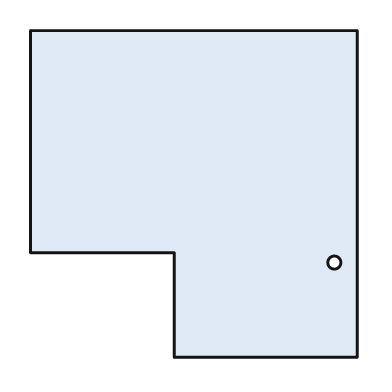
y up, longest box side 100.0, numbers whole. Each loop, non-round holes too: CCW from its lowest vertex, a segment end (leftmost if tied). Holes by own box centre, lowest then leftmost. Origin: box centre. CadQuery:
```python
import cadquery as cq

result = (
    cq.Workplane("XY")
    .moveTo(-6.0, -50.0)
    .lineTo(50.0, -50.0)
    .lineTo(50.0, 50.0)
    .lineTo(-50.0, 50.0)
    .lineTo(-50.0, -18.0)
    .lineTo(-6.0, -18.0)
    .close()
    .moveTo(43.0, -21.0)
    .circle(2.0)
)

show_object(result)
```